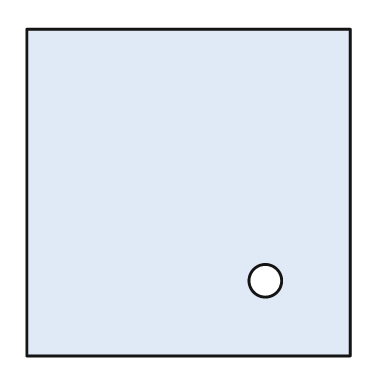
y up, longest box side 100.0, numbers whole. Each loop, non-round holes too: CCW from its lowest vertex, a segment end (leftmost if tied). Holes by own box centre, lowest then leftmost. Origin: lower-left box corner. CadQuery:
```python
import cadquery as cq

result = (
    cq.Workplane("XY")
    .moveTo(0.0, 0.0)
    .lineTo(99.0, 0.0)
    .lineTo(99.0, 100.0)
    .lineTo(0.0, 100.0)
    .close()
    .moveTo(73.0, 23.0)
    .circle(5.0)
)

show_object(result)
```